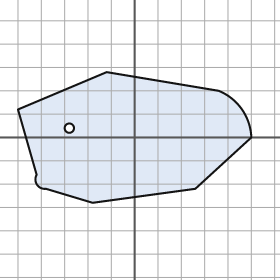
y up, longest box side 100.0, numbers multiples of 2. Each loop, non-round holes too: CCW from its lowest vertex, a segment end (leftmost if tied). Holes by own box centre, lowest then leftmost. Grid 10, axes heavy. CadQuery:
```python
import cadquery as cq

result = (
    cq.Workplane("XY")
    .moveTo(-18.0, -28.0)
    .lineTo(26.0, -22.0)
    .lineTo(50.0, 0.0)
    .threePointArc((46.0, 12.0), (36.0, 20.0))
    .lineTo(-12.0, 28.0)
    .lineTo(-50.0, 12.0)
    .lineTo(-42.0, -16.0)
    .threePointArc((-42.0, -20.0), (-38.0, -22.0))
    .close()
    .moveTo(-28.0, 4.0)
    .circle(2.0)
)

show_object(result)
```